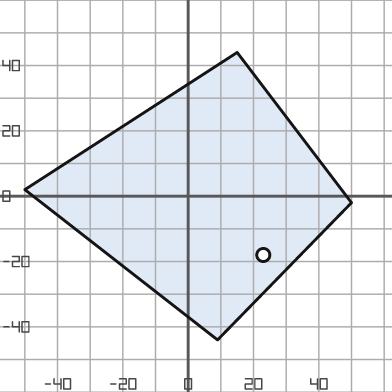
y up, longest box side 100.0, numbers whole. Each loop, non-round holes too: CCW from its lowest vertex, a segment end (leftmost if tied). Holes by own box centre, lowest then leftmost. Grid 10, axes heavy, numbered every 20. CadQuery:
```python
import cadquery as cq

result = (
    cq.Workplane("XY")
    .moveTo(9.0, -44.0)
    .lineTo(50.0, -2.0)
    .lineTo(15.0, 44.0)
    .lineTo(-50.0, 2.0)
    .close()
    .moveTo(23.0, -18.0)
    .circle(2.0)
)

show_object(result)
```